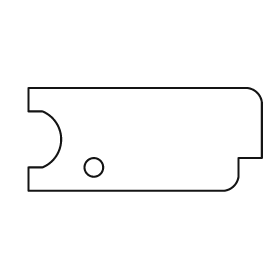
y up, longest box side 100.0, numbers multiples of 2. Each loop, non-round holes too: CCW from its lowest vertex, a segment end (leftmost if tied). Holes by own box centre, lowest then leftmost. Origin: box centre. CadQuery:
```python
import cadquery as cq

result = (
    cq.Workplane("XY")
    .moveTo(-50.0, -22.0)
    .lineTo(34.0, -22.0)
    .threePointArc((38.0, -20.0), (40.0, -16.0))
    .lineTo(40.0, -8.0)
    .lineTo(50.0, -8.0)
    .lineTo(50.0, 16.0)
    .threePointArc((48.0, 20.0), (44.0, 22.0))
    .lineTo(-50.0, 22.0)
    .lineTo(-50.0, 12.0)
    .lineTo(-44.0, 12.0)
    .threePointArc((-36.0, 0.0), (-44.0, -12.0))
    .lineTo(-50.0, -12.0)
    .close()
    .moveTo(-22.0, -12.0)
    .circle(4.0)
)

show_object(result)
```